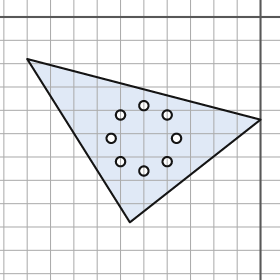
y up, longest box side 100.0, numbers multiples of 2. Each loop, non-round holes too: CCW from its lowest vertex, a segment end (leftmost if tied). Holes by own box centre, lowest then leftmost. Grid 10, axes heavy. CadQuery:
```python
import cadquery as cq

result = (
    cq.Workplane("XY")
    .moveTo(-56.0, -88.0)
    .lineTo(0.0, -44.0)
    .lineTo(-100.0, -18.0)
    .close()
    .moveTo(-50.0, -66.0)
    .circle(2.0)
    .moveTo(-60.0, -62.0)
    .circle(2.0)
    .moveTo(-40.0, -62.0)
    .circle(2.0)
    .moveTo(-64.0, -52.0)
    .circle(2.0)
    .moveTo(-36.0, -52.0)
    .circle(2.0)
    .moveTo(-60.0, -42.0)
    .circle(2.0)
    .moveTo(-40.0, -42.0)
    .circle(2.0)
    .moveTo(-50.0, -38.0)
    .circle(2.0)
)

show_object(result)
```